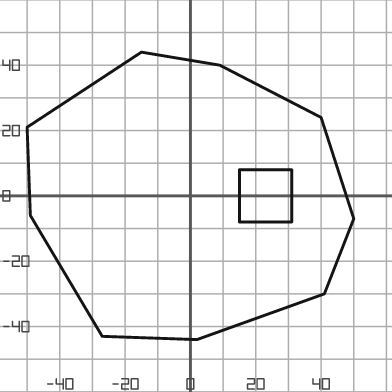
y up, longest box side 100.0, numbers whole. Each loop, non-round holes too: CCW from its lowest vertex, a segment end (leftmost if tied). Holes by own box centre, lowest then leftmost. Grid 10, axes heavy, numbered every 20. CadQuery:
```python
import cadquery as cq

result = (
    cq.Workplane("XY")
    .moveTo(2.0, -44.0)
    .lineTo(41.0, -30.0)
    .lineTo(50.0, -7.0)
    .lineTo(40.0, 24.0)
    .lineTo(9.0, 40.0)
    .lineTo(-15.0, 44.0)
    .lineTo(-50.0, 21.0)
    .lineTo(-49.0, -6.0)
    .lineTo(-27.0, -43.0)
    .close()
    .moveTo(15.0, -8.0)
    .lineTo(31.0, -8.0)
    .lineTo(31.0, 8.0)
    .lineTo(15.0, 8.0)
    .close()
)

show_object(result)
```